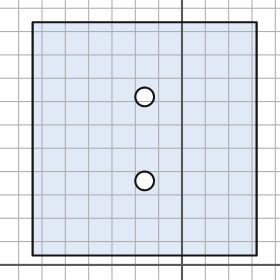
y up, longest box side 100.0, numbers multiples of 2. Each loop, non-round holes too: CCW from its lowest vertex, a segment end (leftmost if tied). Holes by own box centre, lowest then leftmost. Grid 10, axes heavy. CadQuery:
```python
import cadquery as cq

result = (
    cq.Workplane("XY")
    .moveTo(-64.0, 4.0)
    .lineTo(32.0, 4.0)
    .lineTo(32.0, 104.0)
    .lineTo(-64.0, 104.0)
    .close()
    .moveTo(-16.0, 36.0)
    .circle(4.0)
    .moveTo(-16.0, 72.0)
    .circle(4.0)
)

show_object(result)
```